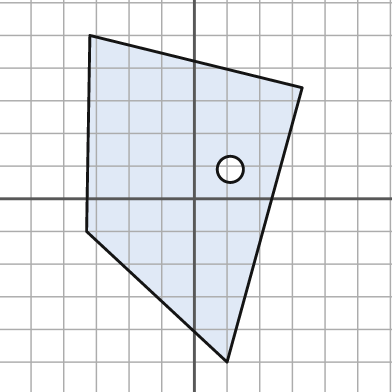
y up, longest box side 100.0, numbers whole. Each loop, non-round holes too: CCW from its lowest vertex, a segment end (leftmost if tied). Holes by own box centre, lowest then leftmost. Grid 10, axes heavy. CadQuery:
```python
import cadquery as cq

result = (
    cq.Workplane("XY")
    .moveTo(10.0, -50.0)
    .lineTo(33.0, 34.0)
    .lineTo(-32.0, 50.0)
    .lineTo(-33.0, -10.0)
    .close()
    .moveTo(11.0, 9.0)
    .circle(4.0)
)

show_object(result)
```